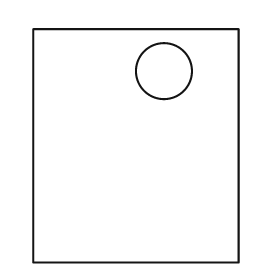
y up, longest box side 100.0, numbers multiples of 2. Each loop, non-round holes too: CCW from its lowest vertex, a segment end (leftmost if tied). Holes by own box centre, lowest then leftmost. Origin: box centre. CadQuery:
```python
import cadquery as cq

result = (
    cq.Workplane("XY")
    .moveTo(-44.0, -50.0)
    .lineTo(44.0, -50.0)
    .lineTo(44.0, 50.0)
    .lineTo(-44.0, 50.0)
    .close()
    .moveTo(12.0, 32.0)
    .circle(12.0)
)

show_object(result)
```